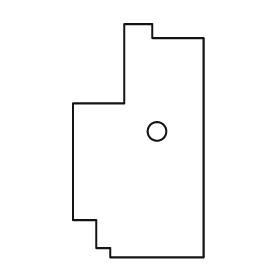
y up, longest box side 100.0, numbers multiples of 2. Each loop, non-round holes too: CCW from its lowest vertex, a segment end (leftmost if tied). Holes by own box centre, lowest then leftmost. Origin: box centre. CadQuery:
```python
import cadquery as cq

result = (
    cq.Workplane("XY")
    .moveTo(-12.0, -50.0)
    .lineTo(28.0, -50.0)
    .lineTo(28.0, 44.0)
    .lineTo(6.0, 44.0)
    .lineTo(6.0, 50.0)
    .lineTo(-6.0, 50.0)
    .lineTo(-6.0, 16.0)
    .lineTo(-28.0, 16.0)
    .lineTo(-28.0, -34.0)
    .lineTo(-18.0, -34.0)
    .lineTo(-18.0, -46.0)
    .lineTo(-12.0, -46.0)
    .close()
    .moveTo(8.0, 4.0)
    .circle(4.0)
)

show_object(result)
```